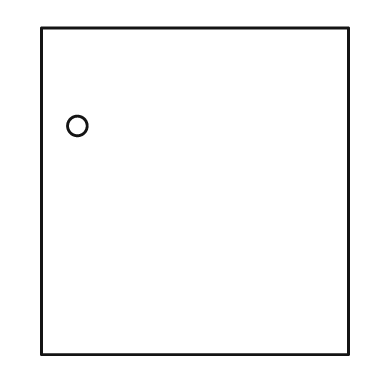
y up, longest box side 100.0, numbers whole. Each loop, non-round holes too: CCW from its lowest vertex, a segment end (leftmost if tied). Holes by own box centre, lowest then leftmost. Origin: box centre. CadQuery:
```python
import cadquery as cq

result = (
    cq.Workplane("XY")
    .moveTo(-47.0, -50.0)
    .lineTo(47.0, -50.0)
    .lineTo(47.0, 50.0)
    .lineTo(-47.0, 50.0)
    .close()
    .moveTo(-36.0, 20.0)
    .circle(3.0)
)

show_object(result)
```